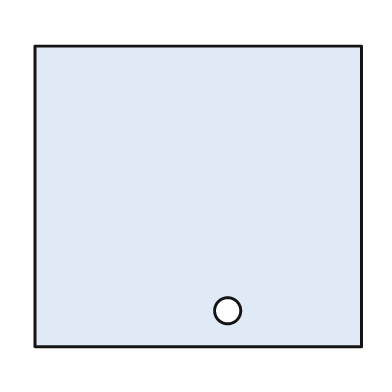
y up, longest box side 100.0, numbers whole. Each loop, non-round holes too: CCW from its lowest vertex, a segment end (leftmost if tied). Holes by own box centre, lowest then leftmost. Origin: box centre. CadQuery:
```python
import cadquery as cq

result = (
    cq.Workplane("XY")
    .moveTo(-50.0, -46.0)
    .lineTo(50.0, -46.0)
    .lineTo(50.0, 46.0)
    .lineTo(-50.0, 46.0)
    .close()
    .moveTo(9.0, -35.0)
    .circle(4.0)
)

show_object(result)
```